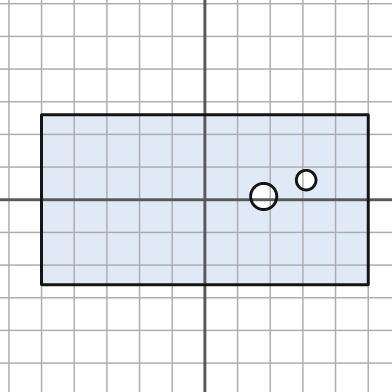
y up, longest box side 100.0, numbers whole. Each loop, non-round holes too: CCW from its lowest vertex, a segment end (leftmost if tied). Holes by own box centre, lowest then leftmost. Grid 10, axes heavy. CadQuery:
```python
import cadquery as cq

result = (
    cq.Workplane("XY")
    .moveTo(-50.0, -26.0)
    .lineTo(50.0, -26.0)
    .lineTo(50.0, 26.0)
    .lineTo(-50.0, 26.0)
    .close()
    .moveTo(18.0, 1.0)
    .circle(4.0)
    .moveTo(31.0, 6.0)
    .circle(3.0)
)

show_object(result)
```